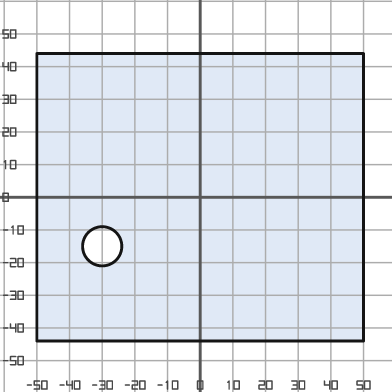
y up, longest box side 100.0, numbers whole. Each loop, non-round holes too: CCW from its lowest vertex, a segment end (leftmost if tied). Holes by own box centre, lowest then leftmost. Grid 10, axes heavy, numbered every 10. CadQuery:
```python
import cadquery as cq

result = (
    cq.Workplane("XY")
    .moveTo(-50.0, -44.0)
    .lineTo(50.0, -44.0)
    .lineTo(50.0, 44.0)
    .lineTo(-50.0, 44.0)
    .close()
    .moveTo(-30.0, -15.0)
    .circle(6.0)
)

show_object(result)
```